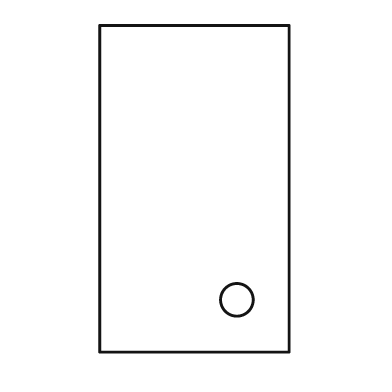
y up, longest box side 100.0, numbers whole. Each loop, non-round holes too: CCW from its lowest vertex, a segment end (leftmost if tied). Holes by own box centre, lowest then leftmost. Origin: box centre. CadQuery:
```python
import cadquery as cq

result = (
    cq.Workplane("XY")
    .moveTo(-29.0, -50.0)
    .lineTo(29.0, -50.0)
    .lineTo(29.0, 50.0)
    .lineTo(-29.0, 50.0)
    .close()
    .moveTo(13.0, -34.0)
    .circle(5.0)
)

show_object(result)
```